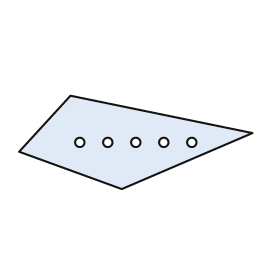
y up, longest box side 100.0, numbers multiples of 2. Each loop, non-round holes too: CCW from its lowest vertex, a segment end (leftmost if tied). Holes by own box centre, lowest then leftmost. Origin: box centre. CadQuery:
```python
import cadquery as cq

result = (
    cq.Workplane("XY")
    .moveTo(-6.0, -20.0)
    .lineTo(50.0, 4.0)
    .lineTo(-28.0, 20.0)
    .lineTo(-50.0, -4.0)
    .close()
    .moveTo(-24.0, 0.0)
    .circle(2.0)
    .moveTo(-12.0, 0.0)
    .circle(2.0)
    .moveTo(0.0, 0.0)
    .circle(2.0)
    .moveTo(12.0, 0.0)
    .circle(2.0)
    .moveTo(24.0, 0.0)
    .circle(2.0)
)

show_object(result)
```